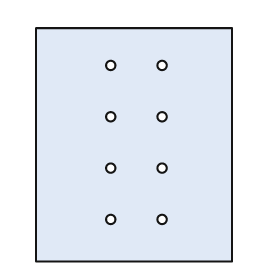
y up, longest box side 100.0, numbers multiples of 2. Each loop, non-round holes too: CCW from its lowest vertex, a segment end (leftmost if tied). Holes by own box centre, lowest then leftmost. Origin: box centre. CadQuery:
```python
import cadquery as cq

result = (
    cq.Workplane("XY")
    .moveTo(-42.0, -50.0)
    .lineTo(42.0, -50.0)
    .lineTo(42.0, 50.0)
    .lineTo(-42.0, 50.0)
    .close()
    .moveTo(-10.0, -32.0)
    .circle(2.0)
    .moveTo(12.0, -32.0)
    .circle(2.0)
    .moveTo(-10.0, -10.0)
    .circle(2.0)
    .moveTo(12.0, -10.0)
    .circle(2.0)
    .moveTo(-10.0, 12.0)
    .circle(2.0)
    .moveTo(12.0, 12.0)
    .circle(2.0)
    .moveTo(-10.0, 34.0)
    .circle(2.0)
    .moveTo(12.0, 34.0)
    .circle(2.0)
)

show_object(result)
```